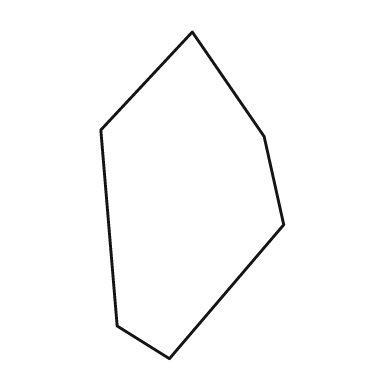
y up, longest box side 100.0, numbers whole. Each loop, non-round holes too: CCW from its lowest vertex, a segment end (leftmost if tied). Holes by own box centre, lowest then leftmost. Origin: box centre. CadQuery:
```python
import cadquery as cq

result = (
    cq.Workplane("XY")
    .moveTo(-7.0, -50.0)
    .lineTo(28.0, -9.0)
    .lineTo(22.0, 18.0)
    .lineTo(0.0, 50.0)
    .lineTo(-28.0, 20.0)
    .lineTo(-23.0, -40.0)
    .close()
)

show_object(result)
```